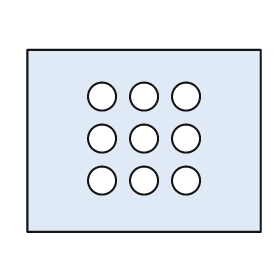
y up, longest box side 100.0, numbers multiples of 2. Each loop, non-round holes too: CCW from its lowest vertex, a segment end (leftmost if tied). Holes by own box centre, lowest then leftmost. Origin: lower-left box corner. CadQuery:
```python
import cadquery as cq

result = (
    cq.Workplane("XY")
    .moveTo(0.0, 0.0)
    .lineTo(100.0, 0.0)
    .lineTo(100.0, 78.0)
    .lineTo(0.0, 78.0)
    .close()
    .moveTo(32.0, 22.0)
    .circle(6.0)
    .moveTo(50.0, 22.0)
    .circle(6.0)
    .moveTo(68.0, 22.0)
    .circle(6.0)
    .moveTo(32.0, 40.0)
    .circle(6.0)
    .moveTo(50.0, 40.0)
    .circle(6.0)
    .moveTo(68.0, 40.0)
    .circle(6.0)
    .moveTo(32.0, 58.0)
    .circle(6.0)
    .moveTo(50.0, 58.0)
    .circle(6.0)
    .moveTo(68.0, 58.0)
    .circle(6.0)
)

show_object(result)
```